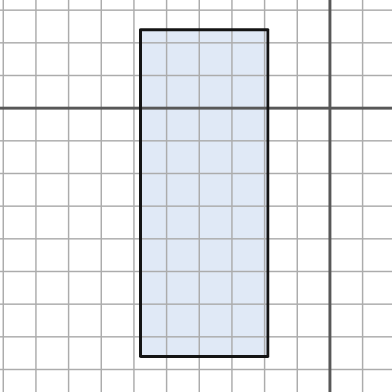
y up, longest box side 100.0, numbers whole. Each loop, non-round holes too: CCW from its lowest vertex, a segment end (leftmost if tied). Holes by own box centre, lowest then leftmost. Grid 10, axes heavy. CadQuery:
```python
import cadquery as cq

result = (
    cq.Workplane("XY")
    .moveTo(-58.0, -76.0)
    .lineTo(-19.0, -76.0)
    .lineTo(-19.0, 24.0)
    .lineTo(-58.0, 24.0)
    .close()
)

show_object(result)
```